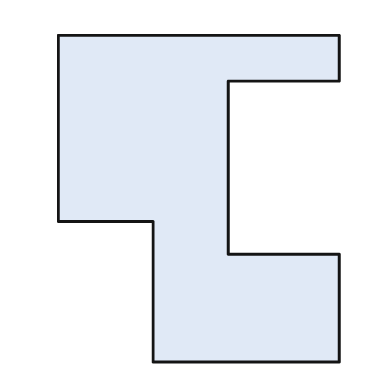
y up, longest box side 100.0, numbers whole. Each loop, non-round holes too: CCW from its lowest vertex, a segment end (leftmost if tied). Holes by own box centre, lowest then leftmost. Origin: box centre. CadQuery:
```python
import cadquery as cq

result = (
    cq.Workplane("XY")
    .moveTo(-14.0, -50.0)
    .lineTo(43.0, -50.0)
    .lineTo(43.0, -17.0)
    .lineTo(9.0, -17.0)
    .lineTo(9.0, 36.0)
    .lineTo(43.0, 36.0)
    .lineTo(43.0, 50.0)
    .lineTo(-43.0, 50.0)
    .lineTo(-43.0, -7.0)
    .lineTo(-14.0, -7.0)
    .close()
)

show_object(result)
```